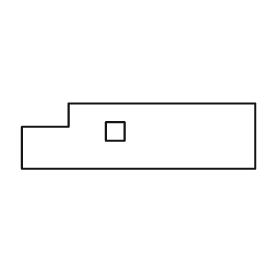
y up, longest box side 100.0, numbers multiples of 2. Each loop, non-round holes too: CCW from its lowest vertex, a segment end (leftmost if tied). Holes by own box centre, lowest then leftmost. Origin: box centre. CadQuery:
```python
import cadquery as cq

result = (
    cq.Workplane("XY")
    .moveTo(-50.0, -14.0)
    .lineTo(50.0, -14.0)
    .lineTo(50.0, 14.0)
    .lineTo(-30.0, 14.0)
    .lineTo(-30.0, 4.0)
    .lineTo(-50.0, 4.0)
    .close()
    .moveTo(-14.0, -2.0)
    .lineTo(-6.0, -2.0)
    .lineTo(-6.0, 6.0)
    .lineTo(-14.0, 6.0)
    .close()
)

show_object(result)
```